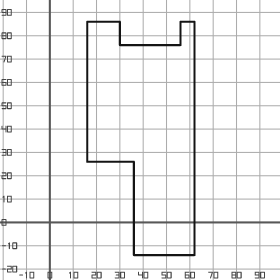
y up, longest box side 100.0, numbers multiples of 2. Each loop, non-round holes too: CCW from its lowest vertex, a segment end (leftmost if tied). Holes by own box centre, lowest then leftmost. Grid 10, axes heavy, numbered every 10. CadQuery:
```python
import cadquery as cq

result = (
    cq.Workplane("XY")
    .moveTo(36.0, -14.0)
    .lineTo(62.0, -14.0)
    .lineTo(62.0, 86.0)
    .lineTo(56.0, 86.0)
    .lineTo(56.0, 76.0)
    .lineTo(30.0, 76.0)
    .lineTo(30.0, 86.0)
    .lineTo(16.0, 86.0)
    .lineTo(16.0, 26.0)
    .lineTo(36.0, 26.0)
    .close()
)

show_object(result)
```